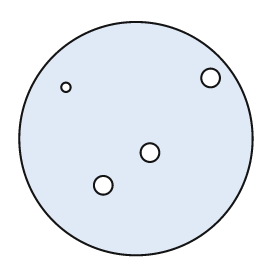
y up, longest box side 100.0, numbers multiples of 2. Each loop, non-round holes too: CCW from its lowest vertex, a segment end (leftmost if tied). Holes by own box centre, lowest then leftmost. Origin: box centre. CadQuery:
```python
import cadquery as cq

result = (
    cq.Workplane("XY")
    .moveTo(0.0, 0.0)
    .circle(50.0)
    .moveTo(-14.0, -20.0)
    .circle(4.0)
    .moveTo(6.0, -6.0)
    .circle(4.0)
    .moveTo(-30.0, 22.0)
    .circle(2.0)
    .moveTo(32.0, 26.0)
    .circle(4.0)
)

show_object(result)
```